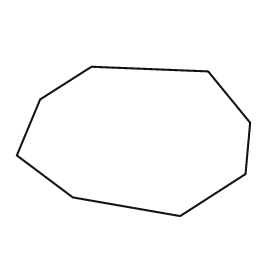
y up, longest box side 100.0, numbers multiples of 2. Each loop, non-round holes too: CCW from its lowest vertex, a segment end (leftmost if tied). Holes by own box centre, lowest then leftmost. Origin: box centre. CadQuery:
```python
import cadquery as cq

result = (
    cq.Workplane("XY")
    .moveTo(20.0, -32.0)
    .lineTo(48.0, -14.0)
    .lineTo(50.0, 8.0)
    .lineTo(32.0, 30.0)
    .lineTo(-18.0, 32.0)
    .lineTo(-40.0, 18.0)
    .lineTo(-50.0, -6.0)
    .lineTo(-26.0, -24.0)
    .close()
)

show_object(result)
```